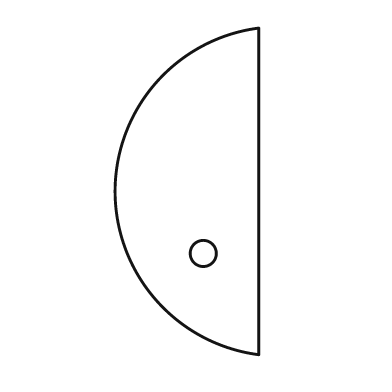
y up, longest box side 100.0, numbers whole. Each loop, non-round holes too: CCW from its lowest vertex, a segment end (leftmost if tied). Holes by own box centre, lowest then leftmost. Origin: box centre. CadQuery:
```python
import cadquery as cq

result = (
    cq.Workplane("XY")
    .moveTo(22.0, -50.0)
    .lineTo(22.0, 50.0)
    .threePointArc((-22.0, 0.0), (22.0, -50.0))
    .close()
    .moveTo(5.0, -19.0)
    .circle(4.0)
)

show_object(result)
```